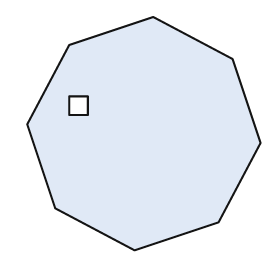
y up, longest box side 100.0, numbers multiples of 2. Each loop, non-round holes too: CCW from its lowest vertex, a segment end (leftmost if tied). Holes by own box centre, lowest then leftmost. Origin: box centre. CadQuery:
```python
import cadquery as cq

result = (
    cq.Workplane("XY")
    .moveTo(-4.0, -50.0)
    .lineTo(32.0, -38.0)
    .lineTo(50.0, -4.0)
    .lineTo(38.0, 32.0)
    .lineTo(4.0, 50.0)
    .lineTo(-32.0, 38.0)
    .lineTo(-50.0, 4.0)
    .lineTo(-38.0, -32.0)
    .close()
    .moveTo(-32.0, 8.0)
    .lineTo(-24.0, 8.0)
    .lineTo(-24.0, 16.0)
    .lineTo(-32.0, 16.0)
    .close()
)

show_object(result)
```